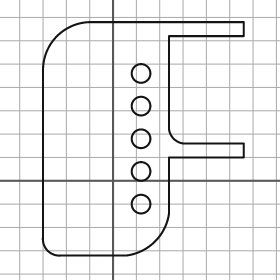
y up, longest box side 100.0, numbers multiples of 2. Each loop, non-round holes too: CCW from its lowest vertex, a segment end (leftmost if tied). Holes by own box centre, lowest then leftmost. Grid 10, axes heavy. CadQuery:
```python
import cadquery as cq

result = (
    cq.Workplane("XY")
    .moveTo(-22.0, -32.0)
    .lineTo(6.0, -32.0)
    .threePointArc((18.0, -26.0), (24.0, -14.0))
    .lineTo(24.0, 10.0)
    .lineTo(56.0, 10.0)
    .lineTo(56.0, 16.0)
    .lineTo(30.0, 16.0)
    .threePointArc((26.0, 18.0), (24.0, 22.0))
    .lineTo(24.0, 62.0)
    .lineTo(56.0, 62.0)
    .lineTo(56.0, 68.0)
    .lineTo(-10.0, 68.0)
    .threePointArc((-24.0, 62.0), (-30.0, 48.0))
    .lineTo(-30.0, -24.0)
    .threePointArc((-28.0, -30.0), (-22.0, -32.0))
    .close()
    .moveTo(12.0, -10.0)
    .circle(4.0)
    .moveTo(12.0, 4.0)
    .circle(4.0)
    .moveTo(12.0, 18.0)
    .circle(4.0)
    .moveTo(12.0, 32.0)
    .circle(4.0)
    .moveTo(12.0, 46.0)
    .circle(4.0)
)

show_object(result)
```